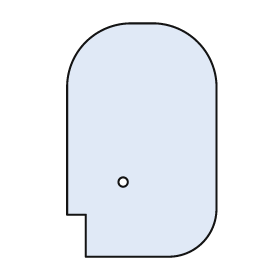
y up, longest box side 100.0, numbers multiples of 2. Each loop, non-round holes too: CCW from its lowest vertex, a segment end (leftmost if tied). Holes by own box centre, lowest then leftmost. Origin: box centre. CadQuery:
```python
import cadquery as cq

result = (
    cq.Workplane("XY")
    .moveTo(-24.0, -50.0)
    .lineTo(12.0, -50.0)
    .threePointArc((26.0, -44.0), (32.0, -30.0))
    .lineTo(32.0, 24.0)
    .threePointArc((24.0, 42.0), (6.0, 50.0))
    .lineTo(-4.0, 50.0)
    .threePointArc((-24.0, 42.0), (-32.0, 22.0))
    .lineTo(-32.0, -32.0)
    .lineTo(-24.0, -32.0)
    .close()
    .moveTo(-8.0, -18.0)
    .circle(2.0)
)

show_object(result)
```